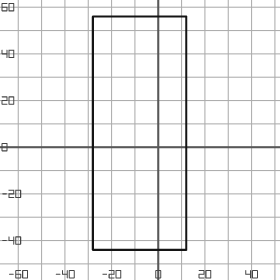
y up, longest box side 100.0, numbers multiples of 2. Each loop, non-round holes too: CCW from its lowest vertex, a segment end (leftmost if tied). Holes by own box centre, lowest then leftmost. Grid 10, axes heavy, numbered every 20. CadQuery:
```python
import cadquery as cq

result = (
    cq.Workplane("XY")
    .moveTo(-28.0, -44.0)
    .lineTo(12.0, -44.0)
    .lineTo(12.0, 56.0)
    .lineTo(-28.0, 56.0)
    .close()
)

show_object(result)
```